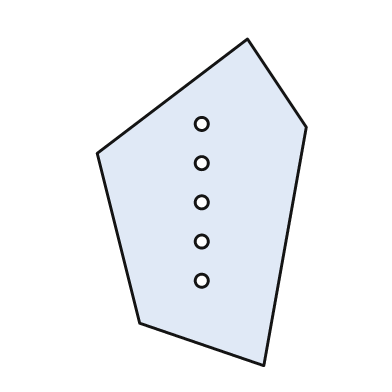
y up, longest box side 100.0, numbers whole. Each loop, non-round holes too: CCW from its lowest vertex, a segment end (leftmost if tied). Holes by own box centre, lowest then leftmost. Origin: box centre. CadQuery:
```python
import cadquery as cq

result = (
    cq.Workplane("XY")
    .moveTo(19.0, -50.0)
    .lineTo(32.0, 23.0)
    .lineTo(14.0, 50.0)
    .lineTo(-32.0, 15.0)
    .lineTo(-19.0, -37.0)
    .close()
    .moveTo(0.0, -24.0)
    .circle(2.0)
    .moveTo(0.0, -12.0)
    .circle(2.0)
    .moveTo(0.0, 0.0)
    .circle(2.0)
    .moveTo(0.0, 12.0)
    .circle(2.0)
    .moveTo(0.0, 24.0)
    .circle(2.0)
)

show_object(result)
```